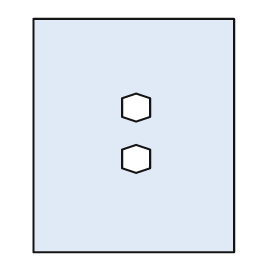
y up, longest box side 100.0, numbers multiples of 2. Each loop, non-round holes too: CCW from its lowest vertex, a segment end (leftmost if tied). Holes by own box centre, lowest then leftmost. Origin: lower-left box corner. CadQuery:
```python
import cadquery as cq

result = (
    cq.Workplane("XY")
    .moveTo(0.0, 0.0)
    .lineTo(86.0, 0.0)
    .lineTo(86.0, 100.0)
    .lineTo(0.0, 100.0)
    .close()
    .moveTo(44.0, 34.0)
    .lineTo(50.0, 36.0)
    .lineTo(50.0, 44.0)
    .lineTo(44.0, 46.0)
    .lineTo(38.0, 44.0)
    .lineTo(38.0, 36.0)
    .close()
    .moveTo(44.0, 56.0)
    .lineTo(50.0, 58.0)
    .lineTo(50.0, 66.0)
    .lineTo(44.0, 68.0)
    .lineTo(38.0, 66.0)
    .lineTo(38.0, 58.0)
    .close()
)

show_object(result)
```